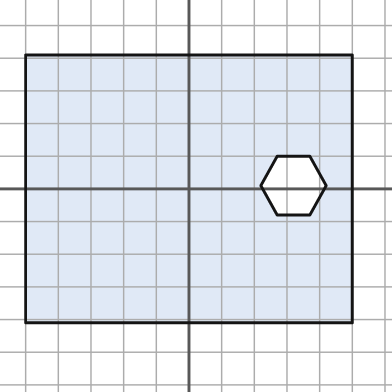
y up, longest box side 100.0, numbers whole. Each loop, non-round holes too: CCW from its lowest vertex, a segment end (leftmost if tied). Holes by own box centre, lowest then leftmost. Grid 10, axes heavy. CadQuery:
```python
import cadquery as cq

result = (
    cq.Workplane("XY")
    .moveTo(-50.0, -41.0)
    .lineTo(50.0, -41.0)
    .lineTo(50.0, 41.0)
    .lineTo(-50.0, 41.0)
    .close()
    .moveTo(27.0, -8.0)
    .lineTo(37.0, -8.0)
    .lineTo(42.0, 1.0)
    .lineTo(37.0, 10.0)
    .lineTo(27.0, 10.0)
    .lineTo(22.0, 1.0)
    .close()
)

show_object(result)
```